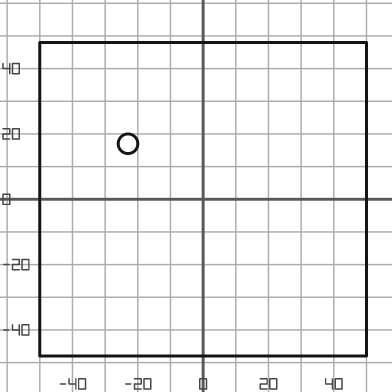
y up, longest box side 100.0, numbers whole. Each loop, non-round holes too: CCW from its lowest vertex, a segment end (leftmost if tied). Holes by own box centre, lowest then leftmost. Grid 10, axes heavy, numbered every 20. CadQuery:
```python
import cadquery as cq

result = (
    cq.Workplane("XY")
    .moveTo(-50.0, -48.0)
    .lineTo(50.0, -48.0)
    .lineTo(50.0, 48.0)
    .lineTo(-50.0, 48.0)
    .close()
    .moveTo(-23.0, 17.0)
    .circle(3.0)
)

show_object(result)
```